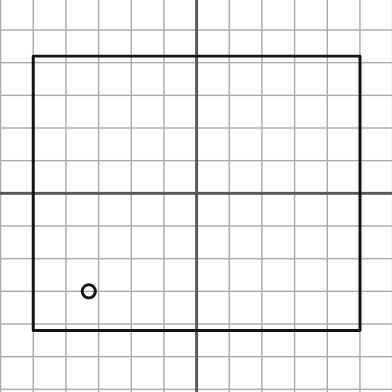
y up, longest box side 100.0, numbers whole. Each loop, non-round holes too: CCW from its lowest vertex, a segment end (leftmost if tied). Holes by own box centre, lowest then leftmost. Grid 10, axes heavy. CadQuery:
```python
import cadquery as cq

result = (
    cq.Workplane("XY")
    .moveTo(-50.0, -42.0)
    .lineTo(50.0, -42.0)
    .lineTo(50.0, 42.0)
    .lineTo(-50.0, 42.0)
    .close()
    .moveTo(-33.0, -30.0)
    .circle(2.0)
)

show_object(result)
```